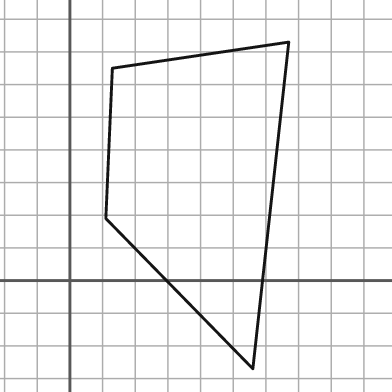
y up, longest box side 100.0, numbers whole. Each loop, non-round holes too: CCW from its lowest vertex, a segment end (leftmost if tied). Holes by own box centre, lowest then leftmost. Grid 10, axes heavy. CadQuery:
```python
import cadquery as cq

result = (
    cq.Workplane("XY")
    .moveTo(56.0, -27.0)
    .lineTo(67.0, 73.0)
    .lineTo(13.0, 65.0)
    .lineTo(11.0, 19.0)
    .close()
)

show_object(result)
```